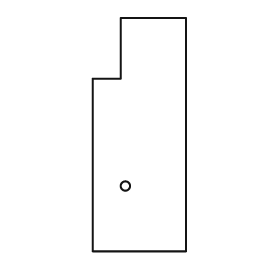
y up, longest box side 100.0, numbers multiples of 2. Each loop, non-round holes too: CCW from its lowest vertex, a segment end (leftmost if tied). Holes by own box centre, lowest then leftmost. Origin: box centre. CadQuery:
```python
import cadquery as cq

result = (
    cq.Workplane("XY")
    .moveTo(-20.0, -50.0)
    .lineTo(20.0, -50.0)
    .lineTo(20.0, 50.0)
    .lineTo(-8.0, 50.0)
    .lineTo(-8.0, 24.0)
    .lineTo(-20.0, 24.0)
    .close()
    .moveTo(-6.0, -22.0)
    .circle(2.0)
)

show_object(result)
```